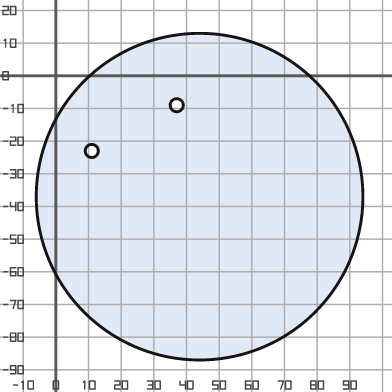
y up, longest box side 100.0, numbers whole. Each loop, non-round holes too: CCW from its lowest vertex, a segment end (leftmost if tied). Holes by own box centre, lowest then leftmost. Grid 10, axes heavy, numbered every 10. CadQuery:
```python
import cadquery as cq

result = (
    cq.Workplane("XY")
    .moveTo(44.0, -37.0)
    .circle(50.0)
    .moveTo(11.0, -23.0)
    .circle(2.0)
    .moveTo(37.0, -9.0)
    .circle(2.0)
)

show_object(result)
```